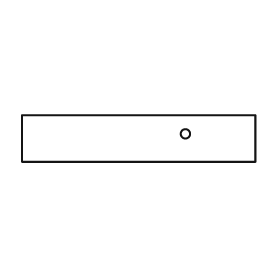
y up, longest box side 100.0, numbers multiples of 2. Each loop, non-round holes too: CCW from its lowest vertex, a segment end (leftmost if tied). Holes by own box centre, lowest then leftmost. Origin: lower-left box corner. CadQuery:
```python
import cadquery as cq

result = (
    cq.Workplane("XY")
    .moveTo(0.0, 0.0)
    .lineTo(100.0, 0.0)
    .lineTo(100.0, 20.0)
    .lineTo(0.0, 20.0)
    .close()
    .moveTo(70.0, 12.0)
    .circle(2.0)
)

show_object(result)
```